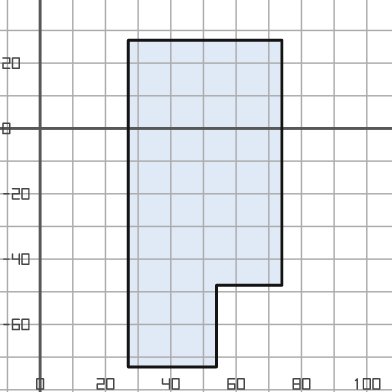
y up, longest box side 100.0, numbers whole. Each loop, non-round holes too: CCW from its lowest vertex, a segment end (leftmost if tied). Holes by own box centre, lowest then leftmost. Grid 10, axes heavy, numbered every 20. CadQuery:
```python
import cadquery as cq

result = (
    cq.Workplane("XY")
    .moveTo(27.0, -73.0)
    .lineTo(54.0, -73.0)
    .lineTo(54.0, -48.0)
    .lineTo(74.0, -48.0)
    .lineTo(74.0, 27.0)
    .lineTo(27.0, 27.0)
    .close()
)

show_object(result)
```